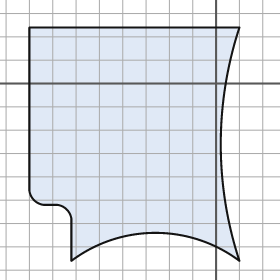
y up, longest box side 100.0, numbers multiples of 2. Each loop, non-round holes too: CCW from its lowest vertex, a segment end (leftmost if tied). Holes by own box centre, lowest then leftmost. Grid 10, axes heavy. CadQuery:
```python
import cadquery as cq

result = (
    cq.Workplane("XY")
    .moveTo(-62.0, -76.0)
    .threePointArc((-26.0, -64.0), (10.0, -76.0))
    .threePointArc((2.0, -26.0), (10.0, 24.0))
    .lineTo(-80.0, 24.0)
    .lineTo(-80.0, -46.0)
    .threePointArc((-78.0, -50.0), (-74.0, -52.0))
    .lineTo(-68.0, -52.0)
    .threePointArc((-64.0, -54.0), (-62.0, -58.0))
    .close()
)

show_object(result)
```